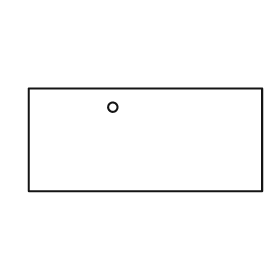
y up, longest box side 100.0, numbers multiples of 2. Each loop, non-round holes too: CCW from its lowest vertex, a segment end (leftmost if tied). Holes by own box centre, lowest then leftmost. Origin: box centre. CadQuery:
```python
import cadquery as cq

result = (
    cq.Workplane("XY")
    .moveTo(-50.0, -22.0)
    .lineTo(50.0, -22.0)
    .lineTo(50.0, 22.0)
    .lineTo(-50.0, 22.0)
    .close()
    .moveTo(-14.0, 14.0)
    .circle(2.0)
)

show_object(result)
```